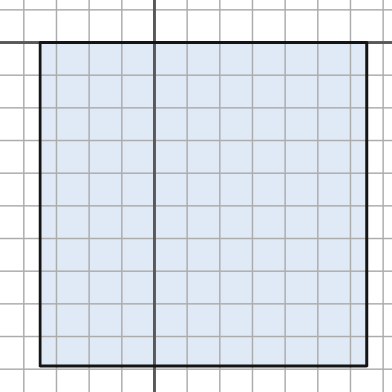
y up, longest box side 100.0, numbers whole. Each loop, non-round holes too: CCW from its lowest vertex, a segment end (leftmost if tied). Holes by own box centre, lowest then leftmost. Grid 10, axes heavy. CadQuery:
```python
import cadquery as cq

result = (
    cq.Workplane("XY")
    .moveTo(-35.0, -99.0)
    .lineTo(65.0, -99.0)
    .lineTo(65.0, 0.0)
    .lineTo(-35.0, 0.0)
    .close()
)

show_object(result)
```